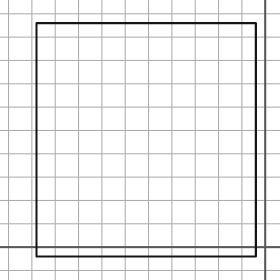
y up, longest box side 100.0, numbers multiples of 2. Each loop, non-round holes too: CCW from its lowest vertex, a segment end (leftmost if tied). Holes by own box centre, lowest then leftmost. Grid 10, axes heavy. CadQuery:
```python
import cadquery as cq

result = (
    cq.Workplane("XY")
    .moveTo(-98.0, -4.0)
    .lineTo(-4.0, -4.0)
    .lineTo(-4.0, 96.0)
    .lineTo(-98.0, 96.0)
    .close()
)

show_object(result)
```